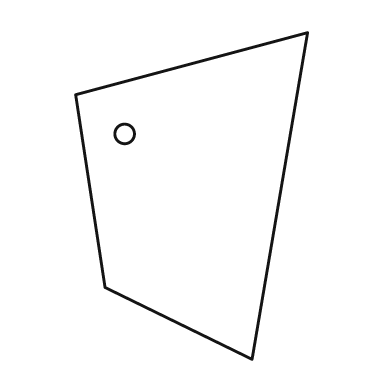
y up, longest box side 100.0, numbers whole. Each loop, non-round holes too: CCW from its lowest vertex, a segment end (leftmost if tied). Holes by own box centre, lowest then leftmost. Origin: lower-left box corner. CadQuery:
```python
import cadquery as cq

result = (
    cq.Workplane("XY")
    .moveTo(54.0, 0.0)
    .lineTo(71.0, 100.0)
    .lineTo(0.0, 81.0)
    .lineTo(9.0, 22.0)
    .close()
    .moveTo(15.0, 69.0)
    .circle(3.0)
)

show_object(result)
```